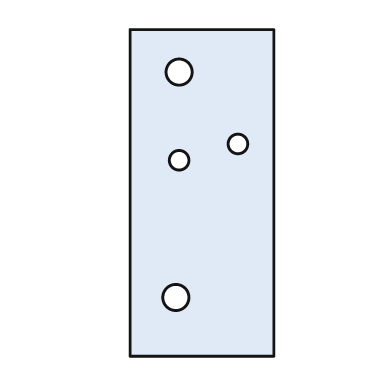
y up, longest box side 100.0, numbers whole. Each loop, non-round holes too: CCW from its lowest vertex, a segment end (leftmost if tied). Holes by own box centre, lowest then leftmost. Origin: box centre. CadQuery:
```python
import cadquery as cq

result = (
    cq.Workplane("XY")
    .moveTo(-22.0, -50.0)
    .lineTo(22.0, -50.0)
    .lineTo(22.0, 50.0)
    .lineTo(-22.0, 50.0)
    .close()
    .moveTo(-8.0, -32.0)
    .circle(4.0)
    .moveTo(-7.0, 10.0)
    .circle(3.0)
    .moveTo(11.0, 15.0)
    .circle(3.0)
    .moveTo(-7.0, 37.0)
    .circle(4.0)
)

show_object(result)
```